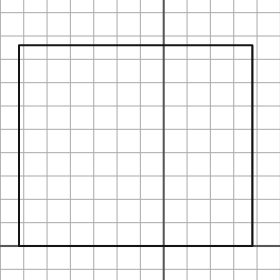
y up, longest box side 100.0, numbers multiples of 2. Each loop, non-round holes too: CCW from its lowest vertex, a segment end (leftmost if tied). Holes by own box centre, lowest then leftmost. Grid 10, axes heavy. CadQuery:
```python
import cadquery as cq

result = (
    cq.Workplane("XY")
    .moveTo(-62.0, 0.0)
    .lineTo(38.0, 0.0)
    .lineTo(38.0, 86.0)
    .lineTo(-62.0, 86.0)
    .close()
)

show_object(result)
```